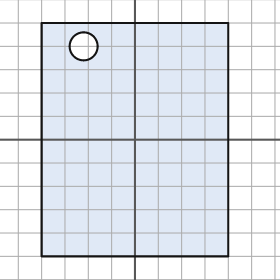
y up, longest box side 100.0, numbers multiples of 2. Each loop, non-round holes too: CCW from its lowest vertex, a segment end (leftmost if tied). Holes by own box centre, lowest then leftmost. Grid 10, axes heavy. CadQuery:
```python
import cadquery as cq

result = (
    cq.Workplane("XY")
    .moveTo(-40.0, -50.0)
    .lineTo(40.0, -50.0)
    .lineTo(40.0, 50.0)
    .lineTo(-40.0, 50.0)
    .close()
    .moveTo(-22.0, 40.0)
    .circle(6.0)
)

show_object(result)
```